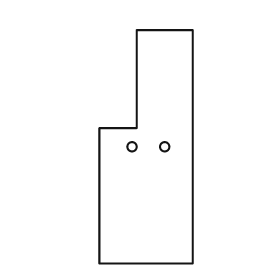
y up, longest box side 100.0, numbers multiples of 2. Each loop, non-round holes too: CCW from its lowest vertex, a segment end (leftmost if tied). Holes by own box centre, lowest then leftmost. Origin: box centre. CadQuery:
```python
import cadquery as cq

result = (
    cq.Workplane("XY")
    .moveTo(-20.0, -50.0)
    .lineTo(20.0, -50.0)
    .lineTo(20.0, 50.0)
    .lineTo(-4.0, 50.0)
    .lineTo(-4.0, 8.0)
    .lineTo(-20.0, 8.0)
    .close()
    .moveTo(-6.0, 0.0)
    .circle(2.0)
    .moveTo(8.0, 0.0)
    .circle(2.0)
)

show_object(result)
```